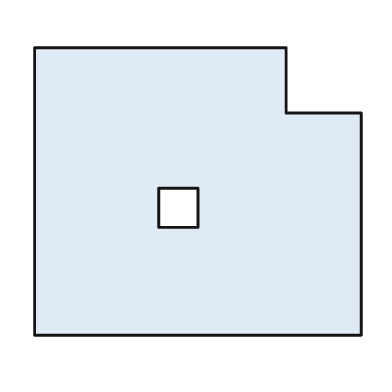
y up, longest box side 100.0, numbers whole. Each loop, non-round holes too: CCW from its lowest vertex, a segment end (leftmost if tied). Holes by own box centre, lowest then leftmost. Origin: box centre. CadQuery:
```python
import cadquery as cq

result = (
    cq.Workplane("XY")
    .moveTo(-50.0, -44.0)
    .lineTo(50.0, -44.0)
    .lineTo(50.0, 24.0)
    .lineTo(27.0, 24.0)
    .lineTo(27.0, 44.0)
    .lineTo(-50.0, 44.0)
    .close()
    .moveTo(-12.0, -11.0)
    .lineTo(0.0, -11.0)
    .lineTo(0.0, 1.0)
    .lineTo(-12.0, 1.0)
    .close()
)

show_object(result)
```